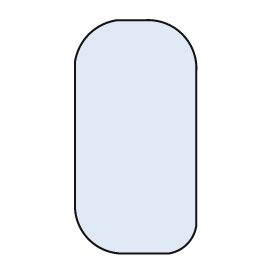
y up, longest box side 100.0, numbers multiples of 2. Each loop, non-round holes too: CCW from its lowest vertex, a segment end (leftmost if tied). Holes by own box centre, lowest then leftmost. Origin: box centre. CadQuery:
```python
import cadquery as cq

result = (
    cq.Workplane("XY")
    .moveTo(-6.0, -50.0)
    .lineTo(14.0, -50.0)
    .threePointArc((22.0, -46.0), (26.0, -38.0))
    .lineTo(26.0, 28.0)
    .threePointArc((20.0, 44.0), (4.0, 50.0))
    .lineTo(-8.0, 50.0)
    .threePointArc((-20.0, 44.0), (-26.0, 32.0))
    .lineTo(-26.0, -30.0)
    .threePointArc((-20.0, -44.0), (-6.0, -50.0))
    .close()
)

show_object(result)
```